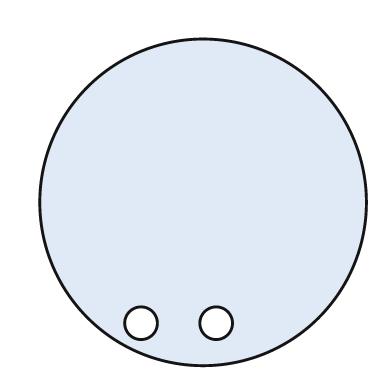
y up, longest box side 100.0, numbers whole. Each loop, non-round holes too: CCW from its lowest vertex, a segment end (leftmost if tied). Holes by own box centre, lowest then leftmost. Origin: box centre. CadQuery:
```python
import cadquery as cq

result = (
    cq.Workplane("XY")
    .moveTo(0.0, 0.0)
    .circle(50.0)
    .moveTo(-19.0, -37.0)
    .circle(5.0)
    .moveTo(4.0, -37.0)
    .circle(5.0)
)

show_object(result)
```